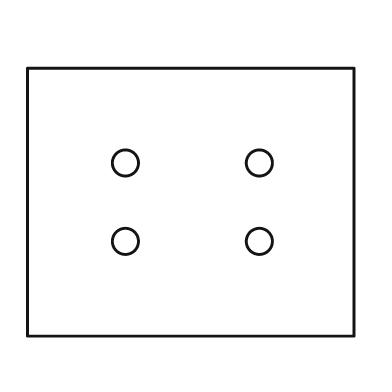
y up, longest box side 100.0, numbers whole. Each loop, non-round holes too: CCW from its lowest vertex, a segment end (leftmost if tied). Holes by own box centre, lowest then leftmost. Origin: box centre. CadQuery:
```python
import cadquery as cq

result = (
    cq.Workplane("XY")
    .moveTo(-50.0, -41.0)
    .lineTo(50.0, -41.0)
    .lineTo(50.0, 41.0)
    .lineTo(-50.0, 41.0)
    .close()
    .moveTo(-20.0, -12.0)
    .circle(4.0)
    .moveTo(21.0, -12.0)
    .circle(4.0)
    .moveTo(-20.0, 12.0)
    .circle(4.0)
    .moveTo(21.0, 12.0)
    .circle(4.0)
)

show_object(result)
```